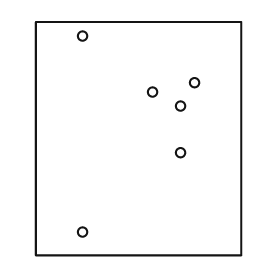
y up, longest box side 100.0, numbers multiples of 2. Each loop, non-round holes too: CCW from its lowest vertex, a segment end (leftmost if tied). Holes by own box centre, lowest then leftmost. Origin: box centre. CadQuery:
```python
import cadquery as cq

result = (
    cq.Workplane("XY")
    .moveTo(-44.0, -50.0)
    .lineTo(44.0, -50.0)
    .lineTo(44.0, 50.0)
    .lineTo(-44.0, 50.0)
    .close()
    .moveTo(-24.0, -40.0)
    .circle(2.0)
    .moveTo(18.0, -6.0)
    .circle(2.0)
    .moveTo(18.0, 14.0)
    .circle(2.0)
    .moveTo(6.0, 20.0)
    .circle(2.0)
    .moveTo(24.0, 24.0)
    .circle(2.0)
    .moveTo(-24.0, 44.0)
    .circle(2.0)
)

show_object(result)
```